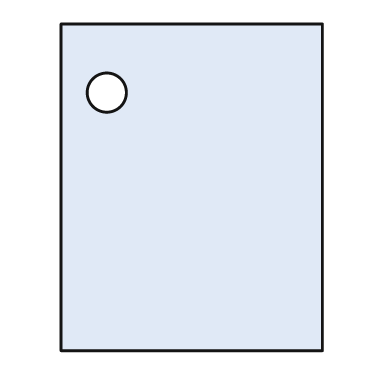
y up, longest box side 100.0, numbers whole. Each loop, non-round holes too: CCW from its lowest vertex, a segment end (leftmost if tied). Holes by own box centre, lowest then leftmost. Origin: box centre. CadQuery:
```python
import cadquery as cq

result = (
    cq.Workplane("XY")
    .moveTo(-40.0, -50.0)
    .lineTo(40.0, -50.0)
    .lineTo(40.0, 50.0)
    .lineTo(-40.0, 50.0)
    .close()
    .moveTo(-26.0, 29.0)
    .circle(6.0)
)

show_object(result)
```